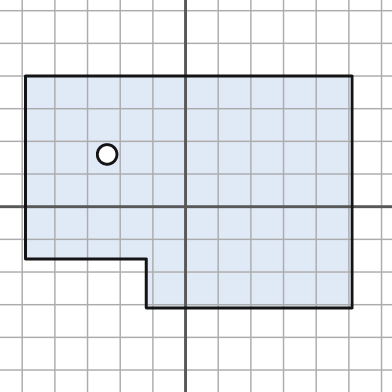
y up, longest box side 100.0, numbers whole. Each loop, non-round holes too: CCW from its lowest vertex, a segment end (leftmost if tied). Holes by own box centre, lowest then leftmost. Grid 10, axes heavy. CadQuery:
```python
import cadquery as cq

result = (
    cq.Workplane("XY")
    .moveTo(-12.0, -31.0)
    .lineTo(51.0, -31.0)
    .lineTo(51.0, 40.0)
    .lineTo(-49.0, 40.0)
    .lineTo(-49.0, -16.0)
    .lineTo(-12.0, -16.0)
    .close()
    .moveTo(-24.0, 16.0)
    .circle(3.0)
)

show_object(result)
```